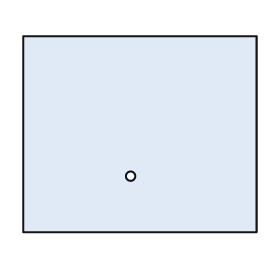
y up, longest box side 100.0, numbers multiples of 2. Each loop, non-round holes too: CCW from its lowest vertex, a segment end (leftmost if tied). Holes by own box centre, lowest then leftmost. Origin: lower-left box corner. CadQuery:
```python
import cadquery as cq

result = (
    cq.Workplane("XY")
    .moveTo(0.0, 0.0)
    .lineTo(100.0, 0.0)
    .lineTo(100.0, 84.0)
    .lineTo(0.0, 84.0)
    .close()
    .moveTo(46.0, 24.0)
    .circle(2.0)
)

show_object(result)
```